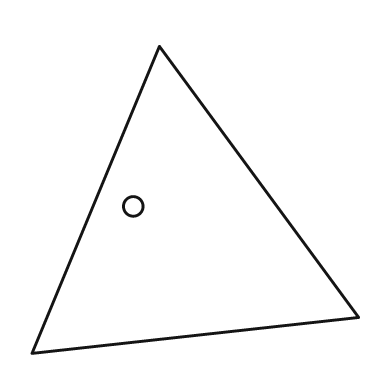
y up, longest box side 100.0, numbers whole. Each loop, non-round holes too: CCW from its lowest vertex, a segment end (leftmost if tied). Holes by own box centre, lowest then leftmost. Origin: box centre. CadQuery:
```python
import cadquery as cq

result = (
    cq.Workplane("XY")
    .moveTo(-50.0, -47.0)
    .lineTo(50.0, -36.0)
    .lineTo(-11.0, 47.0)
    .close()
    .moveTo(-19.0, -2.0)
    .circle(3.0)
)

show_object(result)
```